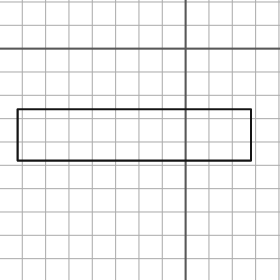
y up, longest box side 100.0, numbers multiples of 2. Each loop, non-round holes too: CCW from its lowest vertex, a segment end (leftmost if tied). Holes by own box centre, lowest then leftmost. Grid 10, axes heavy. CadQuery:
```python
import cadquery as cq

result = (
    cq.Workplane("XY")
    .moveTo(-72.0, -48.0)
    .lineTo(28.0, -48.0)
    .lineTo(28.0, -26.0)
    .lineTo(-72.0, -26.0)
    .close()
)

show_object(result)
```